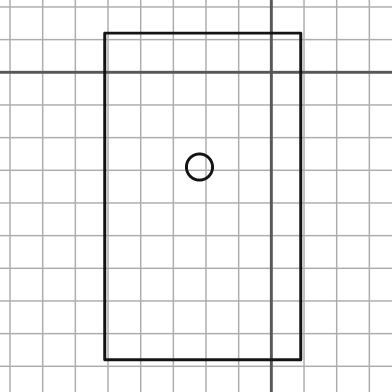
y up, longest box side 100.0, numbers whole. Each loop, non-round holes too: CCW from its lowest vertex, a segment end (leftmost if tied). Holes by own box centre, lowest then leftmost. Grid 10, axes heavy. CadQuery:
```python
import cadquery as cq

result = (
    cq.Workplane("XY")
    .moveTo(-51.0, -88.0)
    .lineTo(9.0, -88.0)
    .lineTo(9.0, 12.0)
    .lineTo(-51.0, 12.0)
    .close()
    .moveTo(-22.0, -29.0)
    .circle(4.0)
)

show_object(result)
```